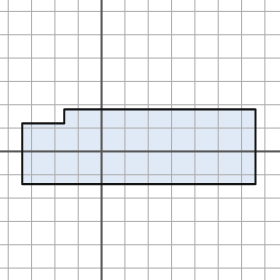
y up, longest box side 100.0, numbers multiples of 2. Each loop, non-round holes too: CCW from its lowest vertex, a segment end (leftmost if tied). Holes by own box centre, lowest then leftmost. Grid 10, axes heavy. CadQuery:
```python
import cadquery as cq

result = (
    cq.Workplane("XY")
    .moveTo(-34.0, -14.0)
    .lineTo(66.0, -14.0)
    .lineTo(66.0, 18.0)
    .lineTo(-16.0, 18.0)
    .lineTo(-16.0, 12.0)
    .lineTo(-34.0, 12.0)
    .close()
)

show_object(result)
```